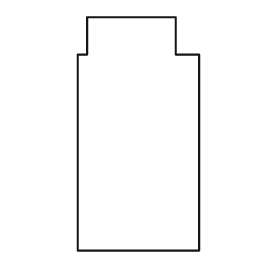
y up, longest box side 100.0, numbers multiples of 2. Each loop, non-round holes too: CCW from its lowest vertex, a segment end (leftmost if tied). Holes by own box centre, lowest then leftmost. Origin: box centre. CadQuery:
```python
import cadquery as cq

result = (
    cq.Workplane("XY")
    .moveTo(-26.0, -50.0)
    .lineTo(26.0, -50.0)
    .lineTo(26.0, 34.0)
    .lineTo(16.0, 34.0)
    .lineTo(16.0, 50.0)
    .lineTo(-22.0, 50.0)
    .lineTo(-22.0, 34.0)
    .lineTo(-26.0, 34.0)
    .close()
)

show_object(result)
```